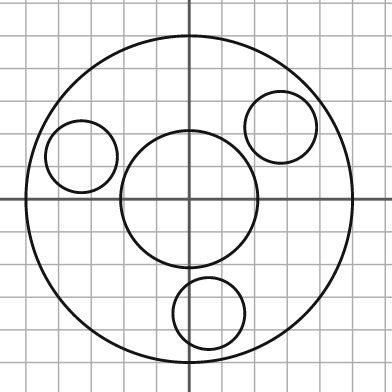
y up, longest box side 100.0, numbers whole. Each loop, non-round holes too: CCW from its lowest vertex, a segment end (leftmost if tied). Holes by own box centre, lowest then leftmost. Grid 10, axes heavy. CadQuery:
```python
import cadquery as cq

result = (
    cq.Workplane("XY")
    .moveTo(0.0, 0.0)
    .circle(50.0)
    .moveTo(6.0, -35.0)
    .circle(11.0)
    .moveTo(0.0, 0.0)
    .circle(21.0)
    .moveTo(-33.0, 13.0)
    .circle(11.0)
    .moveTo(28.0, 22.0)
    .circle(11.0)
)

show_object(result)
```